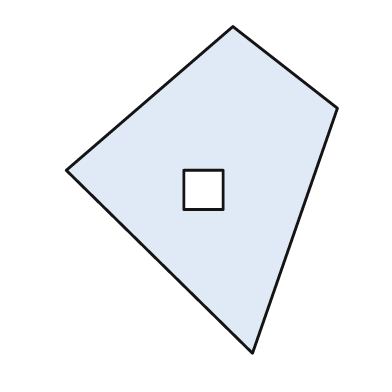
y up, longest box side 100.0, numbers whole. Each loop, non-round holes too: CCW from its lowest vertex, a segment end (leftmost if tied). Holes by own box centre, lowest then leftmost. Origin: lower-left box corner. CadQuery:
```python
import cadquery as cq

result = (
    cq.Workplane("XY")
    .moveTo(57.0, 0.0)
    .lineTo(83.0, 75.0)
    .lineTo(51.0, 100.0)
    .lineTo(0.0, 56.0)
    .close()
    .moveTo(36.0, 44.0)
    .lineTo(48.0, 44.0)
    .lineTo(48.0, 56.0)
    .lineTo(36.0, 56.0)
    .close()
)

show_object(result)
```